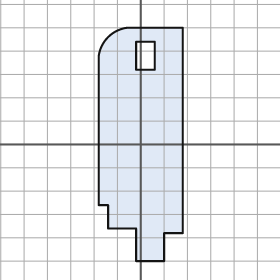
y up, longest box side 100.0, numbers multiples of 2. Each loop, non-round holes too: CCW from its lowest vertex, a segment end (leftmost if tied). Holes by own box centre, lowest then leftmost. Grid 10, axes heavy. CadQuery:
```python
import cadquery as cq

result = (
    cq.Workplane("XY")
    .moveTo(-2.0, -50.0)
    .lineTo(10.0, -50.0)
    .lineTo(10.0, -38.0)
    .lineTo(18.0, -38.0)
    .lineTo(18.0, 50.0)
    .lineTo(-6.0, 50.0)
    .threePointArc((-14.0, 46.0), (-18.0, 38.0))
    .lineTo(-18.0, -26.0)
    .lineTo(-14.0, -26.0)
    .lineTo(-14.0, -36.0)
    .lineTo(-2.0, -36.0)
    .close()
    .moveTo(-2.0, 32.0)
    .lineTo(6.0, 32.0)
    .lineTo(6.0, 44.0)
    .lineTo(-2.0, 44.0)
    .close()
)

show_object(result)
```